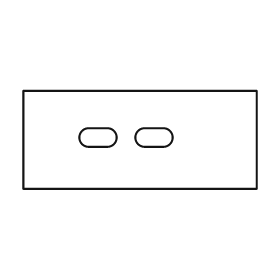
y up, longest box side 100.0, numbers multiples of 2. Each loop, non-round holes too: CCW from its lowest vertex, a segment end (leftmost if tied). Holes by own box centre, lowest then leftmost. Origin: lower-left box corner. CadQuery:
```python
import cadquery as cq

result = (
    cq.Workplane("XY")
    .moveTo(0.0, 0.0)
    .lineTo(100.0, 0.0)
    .lineTo(100.0, 42.0)
    .lineTo(0.0, 42.0)
    .close()
    .moveTo(28.0, 18.0)
    .lineTo(36.0, 18.0)
    .threePointArc((40.0, 22.0), (36.0, 26.0))
    .lineTo(28.0, 26.0)
    .threePointArc((24.0, 22.0), (28.0, 18.0))
    .close()
    .moveTo(52.0, 18.0)
    .lineTo(60.0, 18.0)
    .threePointArc((64.0, 22.0), (60.0, 26.0))
    .lineTo(52.0, 26.0)
    .threePointArc((48.0, 22.0), (52.0, 18.0))
    .close()
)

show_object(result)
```